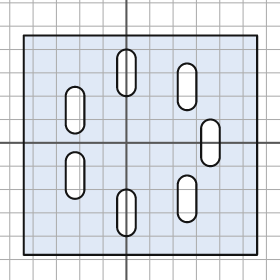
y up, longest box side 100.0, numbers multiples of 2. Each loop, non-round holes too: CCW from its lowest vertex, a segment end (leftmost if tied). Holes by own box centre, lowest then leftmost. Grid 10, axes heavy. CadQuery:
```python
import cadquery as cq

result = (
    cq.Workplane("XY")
    .moveTo(-44.0, -48.0)
    .lineTo(56.0, -48.0)
    .lineTo(56.0, 46.0)
    .lineTo(-44.0, 46.0)
    .close()
    .moveTo(-4.0, -36.0)
    .threePointArc((0.0, -40.0), (4.0, -36.0))
    .lineTo(4.0, -24.0)
    .threePointArc((0.0, -20.0), (-4.0, -24.0))
    .close()
    .moveTo(22.0, -30.0)
    .threePointArc((26.0, -34.0), (30.0, -30.0))
    .lineTo(30.0, -18.0)
    .threePointArc((26.0, -14.0), (22.0, -18.0))
    .close()
    .moveTo(-26.0, -20.0)
    .threePointArc((-22.0, -24.0), (-18.0, -20.0))
    .lineTo(-18.0, -8.0)
    .threePointArc((-22.0, -4.0), (-26.0, -8.0))
    .close()
    .moveTo(32.0, -6.0)
    .threePointArc((36.0, -10.0), (40.0, -6.0))
    .lineTo(40.0, 6.0)
    .threePointArc((36.0, 10.0), (32.0, 6.0))
    .close()
    .moveTo(-26.0, 8.0)
    .threePointArc((-22.0, 4.0), (-18.0, 8.0))
    .lineTo(-18.0, 20.0)
    .threePointArc((-22.0, 24.0), (-26.0, 20.0))
    .close()
    .moveTo(22.0, 18.0)
    .threePointArc((26.0, 14.0), (30.0, 18.0))
    .lineTo(30.0, 30.0)
    .threePointArc((26.0, 34.0), (22.0, 30.0))
    .close()
    .moveTo(-4.0, 24.0)
    .threePointArc((0.0, 20.0), (4.0, 24.0))
    .lineTo(4.0, 36.0)
    .threePointArc((0.0, 40.0), (-4.0, 36.0))
    .close()
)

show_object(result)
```